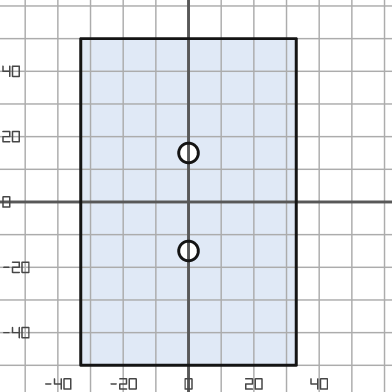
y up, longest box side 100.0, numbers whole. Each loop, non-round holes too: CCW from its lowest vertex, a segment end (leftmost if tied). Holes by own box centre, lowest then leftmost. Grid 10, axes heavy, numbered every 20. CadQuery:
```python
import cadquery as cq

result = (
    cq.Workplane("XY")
    .moveTo(-33.0, -50.0)
    .lineTo(33.0, -50.0)
    .lineTo(33.0, 50.0)
    .lineTo(-33.0, 50.0)
    .close()
    .moveTo(0.0, -15.0)
    .circle(3.0)
    .moveTo(0.0, 15.0)
    .circle(3.0)
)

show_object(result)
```